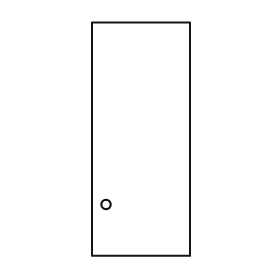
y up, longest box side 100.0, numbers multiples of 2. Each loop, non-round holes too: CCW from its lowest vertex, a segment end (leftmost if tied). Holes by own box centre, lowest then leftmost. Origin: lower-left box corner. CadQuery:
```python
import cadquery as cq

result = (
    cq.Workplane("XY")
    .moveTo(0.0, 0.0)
    .lineTo(42.0, 0.0)
    .lineTo(42.0, 100.0)
    .lineTo(0.0, 100.0)
    .close()
    .moveTo(6.0, 22.0)
    .circle(2.0)
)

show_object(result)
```